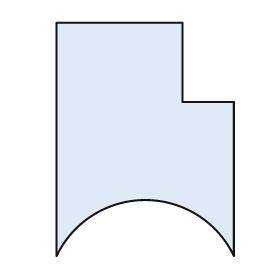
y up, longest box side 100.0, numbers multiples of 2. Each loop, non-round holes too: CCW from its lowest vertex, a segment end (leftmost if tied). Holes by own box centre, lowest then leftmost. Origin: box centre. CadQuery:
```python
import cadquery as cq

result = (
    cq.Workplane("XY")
    .moveTo(-38.0, -50.0)
    .threePointArc((0.0, -26.0), (38.0, -50.0))
    .lineTo(38.0, 16.0)
    .lineTo(16.0, 16.0)
    .lineTo(16.0, 50.0)
    .lineTo(-38.0, 50.0)
    .close()
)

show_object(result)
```